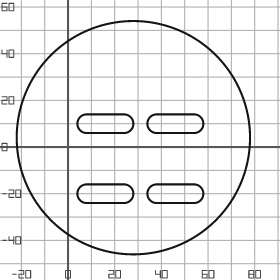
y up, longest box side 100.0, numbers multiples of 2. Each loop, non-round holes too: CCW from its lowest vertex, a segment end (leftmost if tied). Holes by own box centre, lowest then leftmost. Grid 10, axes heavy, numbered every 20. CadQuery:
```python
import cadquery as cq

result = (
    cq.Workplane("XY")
    .moveTo(28.0, 4.0)
    .circle(50.0)
    .moveTo(8.0, -24.0)
    .lineTo(24.0, -24.0)
    .threePointArc((28.0, -20.0), (24.0, -16.0))
    .lineTo(8.0, -16.0)
    .threePointArc((4.0, -20.0), (8.0, -24.0))
    .close()
    .moveTo(38.0, -24.0)
    .lineTo(54.0, -24.0)
    .threePointArc((58.0, -20.0), (54.0, -16.0))
    .lineTo(38.0, -16.0)
    .threePointArc((34.0, -20.0), (38.0, -24.0))
    .close()
    .moveTo(8.0, 6.0)
    .lineTo(24.0, 6.0)
    .threePointArc((28.0, 10.0), (24.0, 14.0))
    .lineTo(8.0, 14.0)
    .threePointArc((4.0, 10.0), (8.0, 6.0))
    .close()
    .moveTo(38.0, 6.0)
    .lineTo(54.0, 6.0)
    .threePointArc((58.0, 10.0), (54.0, 14.0))
    .lineTo(38.0, 14.0)
    .threePointArc((34.0, 10.0), (38.0, 6.0))
    .close()
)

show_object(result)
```